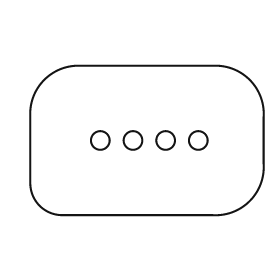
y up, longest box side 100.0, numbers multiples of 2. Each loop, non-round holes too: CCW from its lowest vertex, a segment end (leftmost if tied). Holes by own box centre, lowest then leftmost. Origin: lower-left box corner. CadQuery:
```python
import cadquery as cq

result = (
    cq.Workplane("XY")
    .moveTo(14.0, 0.0)
    .lineTo(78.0, 0.0)
    .threePointArc((94.0, 6.0), (100.0, 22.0))
    .lineTo(100.0, 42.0)
    .threePointArc((94.0, 58.0), (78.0, 64.0))
    .lineTo(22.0, 64.0)
    .threePointArc((6.0, 58.0), (0.0, 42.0))
    .lineTo(0.0, 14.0)
    .threePointArc((4.0, 4.0), (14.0, 0.0))
    .close()
    .moveTo(30.0, 32.0)
    .circle(4.0)
    .moveTo(44.0, 32.0)
    .circle(4.0)
    .moveTo(58.0, 32.0)
    .circle(4.0)
    .moveTo(72.0, 32.0)
    .circle(4.0)
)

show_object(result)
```